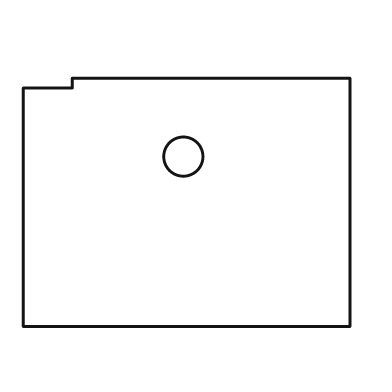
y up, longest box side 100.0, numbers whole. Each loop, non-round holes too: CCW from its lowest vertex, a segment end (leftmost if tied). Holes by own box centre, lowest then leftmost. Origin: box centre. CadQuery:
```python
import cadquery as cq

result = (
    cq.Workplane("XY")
    .moveTo(-50.0, -38.0)
    .lineTo(50.0, -38.0)
    .lineTo(50.0, 38.0)
    .lineTo(-35.0, 38.0)
    .lineTo(-35.0, 35.0)
    .lineTo(-50.0, 35.0)
    .close()
    .moveTo(-1.0, 14.0)
    .circle(6.0)
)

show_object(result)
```